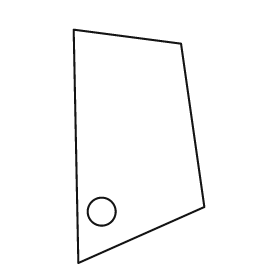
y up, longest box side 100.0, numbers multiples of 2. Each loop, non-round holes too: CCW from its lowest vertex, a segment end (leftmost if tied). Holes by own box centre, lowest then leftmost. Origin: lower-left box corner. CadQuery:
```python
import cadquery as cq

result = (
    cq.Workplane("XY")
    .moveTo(2.0, 0.0)
    .lineTo(56.0, 24.0)
    .lineTo(46.0, 94.0)
    .lineTo(0.0, 100.0)
    .close()
    .moveTo(12.0, 22.0)
    .circle(6.0)
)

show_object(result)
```